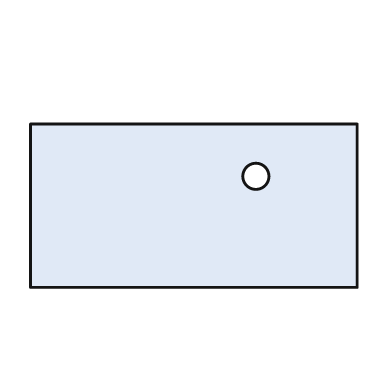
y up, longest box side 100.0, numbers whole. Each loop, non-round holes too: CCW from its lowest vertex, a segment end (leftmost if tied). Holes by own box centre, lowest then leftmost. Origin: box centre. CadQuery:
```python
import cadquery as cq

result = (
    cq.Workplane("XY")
    .moveTo(-50.0, -25.0)
    .lineTo(50.0, -25.0)
    .lineTo(50.0, 25.0)
    .lineTo(-50.0, 25.0)
    .close()
    .moveTo(19.0, 9.0)
    .circle(4.0)
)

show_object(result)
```